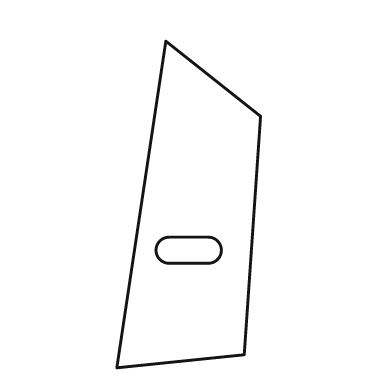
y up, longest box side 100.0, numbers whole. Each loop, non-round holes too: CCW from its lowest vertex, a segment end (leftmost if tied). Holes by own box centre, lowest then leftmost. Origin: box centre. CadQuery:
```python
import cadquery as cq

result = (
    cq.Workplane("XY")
    .moveTo(-22.0, -50.0)
    .lineTo(17.0, -46.0)
    .lineTo(22.0, 27.0)
    .lineTo(-7.0, 50.0)
    .close()
    .moveTo(-6.0, -18.0)
    .lineTo(6.0, -18.0)
    .threePointArc((10.0, -14.0), (6.0, -10.0))
    .lineTo(-6.0, -10.0)
    .threePointArc((-10.0, -14.0), (-6.0, -18.0))
    .close()
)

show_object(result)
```